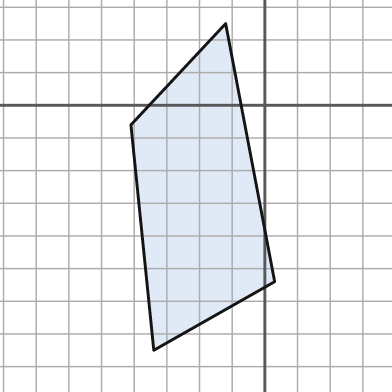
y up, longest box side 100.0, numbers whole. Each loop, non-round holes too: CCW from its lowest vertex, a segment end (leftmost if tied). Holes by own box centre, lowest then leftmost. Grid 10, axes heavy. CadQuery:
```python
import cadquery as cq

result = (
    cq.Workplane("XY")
    .moveTo(-34.0, -75.0)
    .lineTo(3.0, -54.0)
    .lineTo(-12.0, 25.0)
    .lineTo(-41.0, -6.0)
    .close()
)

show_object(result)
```